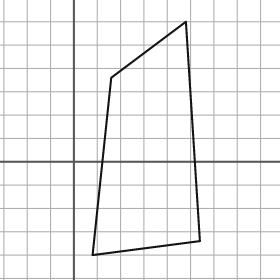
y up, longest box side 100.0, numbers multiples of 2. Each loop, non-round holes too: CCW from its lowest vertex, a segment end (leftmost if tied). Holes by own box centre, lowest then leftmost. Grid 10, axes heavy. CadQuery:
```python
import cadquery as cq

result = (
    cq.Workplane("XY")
    .moveTo(8.0, -40.0)
    .lineTo(54.0, -34.0)
    .lineTo(48.0, 60.0)
    .lineTo(16.0, 36.0)
    .close()
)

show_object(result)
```